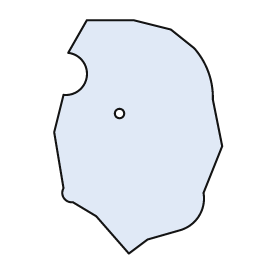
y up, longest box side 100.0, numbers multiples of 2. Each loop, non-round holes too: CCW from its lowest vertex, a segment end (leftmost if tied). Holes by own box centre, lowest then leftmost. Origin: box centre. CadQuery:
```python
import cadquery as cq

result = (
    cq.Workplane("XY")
    .moveTo(-4.0, -50.0)
    .lineTo(4.0, -44.0)
    .lineTo(18.0, -40.0)
    .threePointArc((26.0, -34.0), (28.0, -24.0))
    .lineTo(36.0, -4.0)
    .lineTo(32.0, 16.0)
    .threePointArc((30.0, 28.0), (24.0, 38.0))
    .lineTo(14.0, 46.0)
    .lineTo(-2.0, 50.0)
    .lineTo(-22.0, 50.0)
    .lineTo(-30.0, 36.0)
    .threePointArc((-22.0, 26.0), (-32.0, 18.0))
    .lineTo(-36.0, 2.0)
    .lineTo(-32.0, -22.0)
    .threePointArc((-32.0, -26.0), (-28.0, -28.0))
    .lineTo(-18.0, -34.0)
    .close()
    .moveTo(-8.0, 10.0)
    .circle(2.0)
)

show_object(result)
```